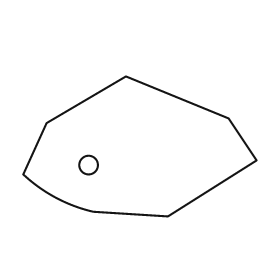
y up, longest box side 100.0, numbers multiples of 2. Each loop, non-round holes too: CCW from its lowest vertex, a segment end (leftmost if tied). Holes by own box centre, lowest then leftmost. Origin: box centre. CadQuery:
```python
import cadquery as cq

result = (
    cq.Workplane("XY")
    .moveTo(12.0, -30.0)
    .lineTo(50.0, -6.0)
    .lineTo(38.0, 12.0)
    .lineTo(-6.0, 30.0)
    .lineTo(-40.0, 10.0)
    .lineTo(-50.0, -12.0)
    .threePointArc((-36.0, -22.0), (-20.0, -28.0))
    .close()
    .moveTo(-22.0, -8.0)
    .circle(4.0)
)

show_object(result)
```